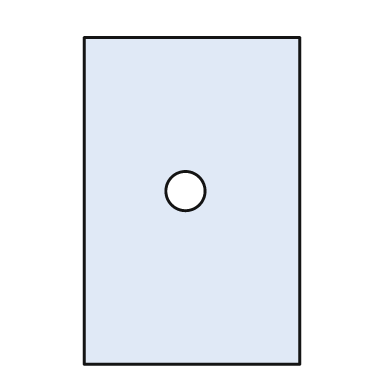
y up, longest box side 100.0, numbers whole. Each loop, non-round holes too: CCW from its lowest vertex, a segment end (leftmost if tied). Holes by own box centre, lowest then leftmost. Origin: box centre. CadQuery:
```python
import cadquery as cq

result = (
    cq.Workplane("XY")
    .moveTo(-33.0, -50.0)
    .lineTo(33.0, -50.0)
    .lineTo(33.0, 50.0)
    .lineTo(-33.0, 50.0)
    .close()
    .moveTo(-2.0, 3.0)
    .circle(6.0)
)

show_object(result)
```